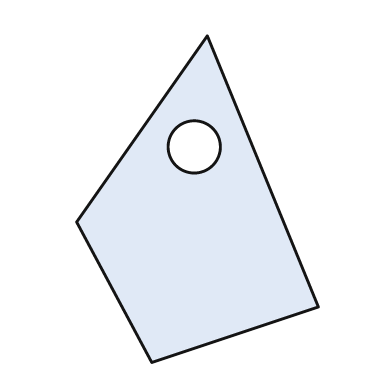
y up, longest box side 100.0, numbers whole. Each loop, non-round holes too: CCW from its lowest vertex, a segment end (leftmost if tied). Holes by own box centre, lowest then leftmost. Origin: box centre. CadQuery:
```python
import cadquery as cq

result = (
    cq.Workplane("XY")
    .moveTo(-14.0, -50.0)
    .lineTo(37.0, -33.0)
    .lineTo(3.0, 50.0)
    .lineTo(-37.0, -7.0)
    .close()
    .moveTo(-1.0, 16.0)
    .circle(8.0)
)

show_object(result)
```